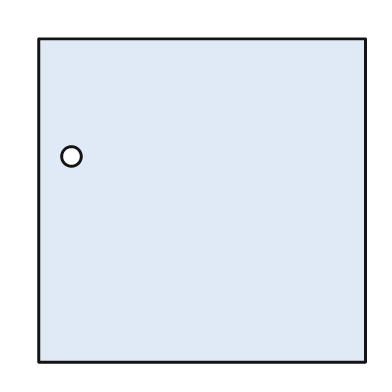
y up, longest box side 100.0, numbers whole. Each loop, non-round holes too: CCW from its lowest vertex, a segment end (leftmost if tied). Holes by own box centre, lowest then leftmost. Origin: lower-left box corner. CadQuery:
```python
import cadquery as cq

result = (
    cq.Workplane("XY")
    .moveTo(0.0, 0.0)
    .lineTo(100.0, 0.0)
    .lineTo(100.0, 99.0)
    .lineTo(0.0, 99.0)
    .close()
    .moveTo(10.0, 63.0)
    .circle(3.0)
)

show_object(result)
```